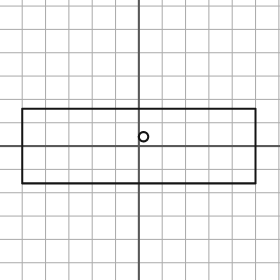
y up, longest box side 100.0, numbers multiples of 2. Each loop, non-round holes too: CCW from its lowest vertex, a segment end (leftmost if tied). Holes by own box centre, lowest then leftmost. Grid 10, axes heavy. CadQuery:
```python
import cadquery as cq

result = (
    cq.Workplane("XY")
    .moveTo(-50.0, -16.0)
    .lineTo(50.0, -16.0)
    .lineTo(50.0, 16.0)
    .lineTo(-50.0, 16.0)
    .close()
    .moveTo(2.0, 4.0)
    .circle(2.0)
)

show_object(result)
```